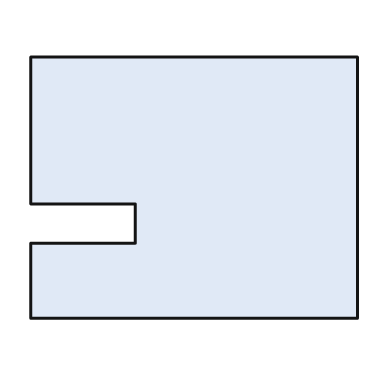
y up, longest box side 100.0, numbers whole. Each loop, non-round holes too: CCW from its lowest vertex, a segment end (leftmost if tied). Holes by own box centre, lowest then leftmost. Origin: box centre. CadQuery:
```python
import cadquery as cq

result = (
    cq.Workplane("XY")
    .moveTo(-50.0, -40.0)
    .lineTo(50.0, -40.0)
    .lineTo(50.0, 40.0)
    .lineTo(-50.0, 40.0)
    .lineTo(-50.0, -5.0)
    .lineTo(-18.0, -5.0)
    .lineTo(-18.0, -17.0)
    .lineTo(-50.0, -17.0)
    .close()
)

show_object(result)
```